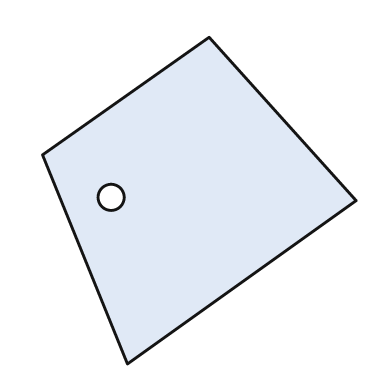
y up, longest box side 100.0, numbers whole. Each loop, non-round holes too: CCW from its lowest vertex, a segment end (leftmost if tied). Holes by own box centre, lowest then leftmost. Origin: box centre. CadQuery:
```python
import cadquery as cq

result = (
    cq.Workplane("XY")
    .moveTo(-22.0, -50.0)
    .lineTo(48.0, 0.0)
    .lineTo(3.0, 50.0)
    .lineTo(-48.0, 14.0)
    .close()
    .moveTo(-27.0, 1.0)
    .circle(4.0)
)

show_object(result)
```